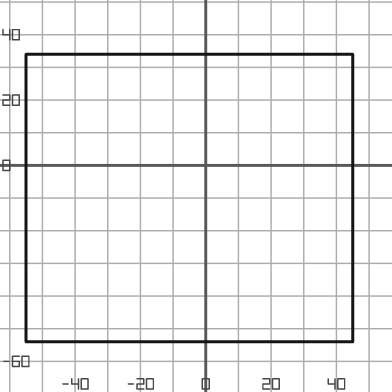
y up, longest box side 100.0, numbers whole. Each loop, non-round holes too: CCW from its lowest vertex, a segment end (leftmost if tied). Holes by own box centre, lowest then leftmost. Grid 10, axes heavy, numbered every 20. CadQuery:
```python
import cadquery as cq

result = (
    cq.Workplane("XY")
    .moveTo(-55.0, -54.0)
    .lineTo(45.0, -54.0)
    .lineTo(45.0, 34.0)
    .lineTo(-55.0, 34.0)
    .close()
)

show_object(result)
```